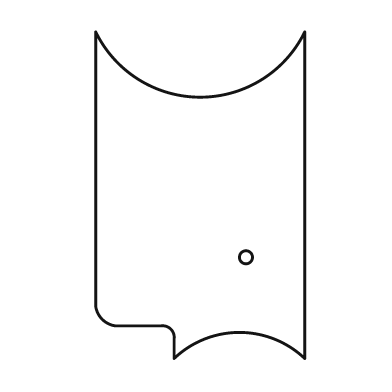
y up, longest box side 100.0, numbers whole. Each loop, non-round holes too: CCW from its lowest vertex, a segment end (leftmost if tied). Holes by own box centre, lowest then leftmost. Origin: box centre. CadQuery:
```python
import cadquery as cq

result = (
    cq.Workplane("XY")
    .moveTo(-8.0, -50.0)
    .threePointArc((12.0, -42.0), (32.0, -50.0))
    .lineTo(32.0, 50.0)
    .threePointArc((0.0, 30.0), (-32.0, 50.0))
    .lineTo(-32.0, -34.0)
    .threePointArc((-30.0, -38.0), (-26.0, -40.0))
    .lineTo(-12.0, -40.0)
    .threePointArc((-9.0, -41.0), (-8.0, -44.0))
    .close()
    .moveTo(14.0, -19.0)
    .circle(2.0)
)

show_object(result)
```